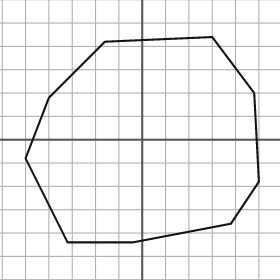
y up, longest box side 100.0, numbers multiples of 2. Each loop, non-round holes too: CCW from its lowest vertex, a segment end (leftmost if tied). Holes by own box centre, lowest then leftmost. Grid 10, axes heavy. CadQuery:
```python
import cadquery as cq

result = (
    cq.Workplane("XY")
    .moveTo(-32.0, -44.0)
    .lineTo(-4.0, -44.0)
    .lineTo(38.0, -36.0)
    .lineTo(50.0, -18.0)
    .lineTo(48.0, 20.0)
    .lineTo(30.0, 44.0)
    .lineTo(-16.0, 42.0)
    .lineTo(-40.0, 18.0)
    .lineTo(-50.0, -8.0)
    .close()
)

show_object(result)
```